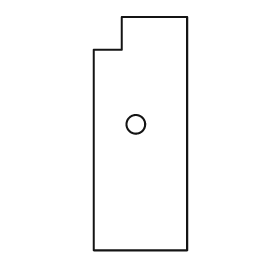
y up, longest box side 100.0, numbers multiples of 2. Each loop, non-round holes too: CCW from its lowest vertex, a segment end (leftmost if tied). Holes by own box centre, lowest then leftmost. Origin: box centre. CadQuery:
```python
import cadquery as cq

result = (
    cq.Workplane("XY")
    .moveTo(-20.0, -50.0)
    .lineTo(20.0, -50.0)
    .lineTo(20.0, 50.0)
    .lineTo(-8.0, 50.0)
    .lineTo(-8.0, 36.0)
    .lineTo(-20.0, 36.0)
    .close()
    .moveTo(-2.0, 4.0)
    .circle(4.0)
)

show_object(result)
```